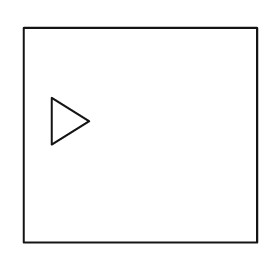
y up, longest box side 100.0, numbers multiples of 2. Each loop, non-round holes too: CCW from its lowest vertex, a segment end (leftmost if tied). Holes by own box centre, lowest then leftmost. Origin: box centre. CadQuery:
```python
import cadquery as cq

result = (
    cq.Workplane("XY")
    .moveTo(-50.0, -46.0)
    .lineTo(50.0, -46.0)
    .lineTo(50.0, 46.0)
    .lineTo(-50.0, 46.0)
    .close()
    .moveTo(-38.0, -4.0)
    .lineTo(-22.0, 6.0)
    .lineTo(-38.0, 16.0)
    .close()
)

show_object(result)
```